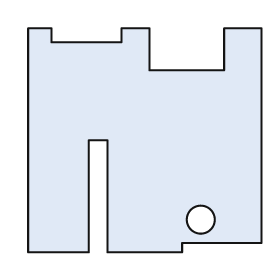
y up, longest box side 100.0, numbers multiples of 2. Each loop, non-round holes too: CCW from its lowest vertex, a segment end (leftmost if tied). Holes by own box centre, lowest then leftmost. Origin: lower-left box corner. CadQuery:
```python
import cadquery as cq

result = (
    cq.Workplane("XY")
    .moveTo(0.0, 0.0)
    .lineTo(26.0, 0.0)
    .lineTo(26.0, 48.0)
    .lineTo(34.0, 48.0)
    .lineTo(34.0, 0.0)
    .lineTo(66.0, 0.0)
    .lineTo(66.0, 4.0)
    .lineTo(100.0, 4.0)
    .lineTo(100.0, 96.0)
    .lineTo(84.0, 96.0)
    .lineTo(84.0, 78.0)
    .lineTo(52.0, 78.0)
    .lineTo(52.0, 96.0)
    .lineTo(40.0, 96.0)
    .lineTo(40.0, 90.0)
    .lineTo(10.0, 90.0)
    .lineTo(10.0, 96.0)
    .lineTo(0.0, 96.0)
    .close()
    .moveTo(74.0, 14.0)
    .circle(6.0)
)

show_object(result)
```